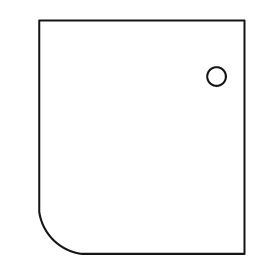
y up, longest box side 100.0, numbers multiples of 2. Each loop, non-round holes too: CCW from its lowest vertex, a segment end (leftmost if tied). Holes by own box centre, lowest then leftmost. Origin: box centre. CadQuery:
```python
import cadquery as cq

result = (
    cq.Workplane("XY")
    .moveTo(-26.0, -50.0)
    .lineTo(44.0, -50.0)
    .lineTo(44.0, 50.0)
    .lineTo(-44.0, 50.0)
    .lineTo(-44.0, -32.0)
    .threePointArc((-38.0, -44.0), (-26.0, -50.0))
    .close()
    .moveTo(32.0, 26.0)
    .circle(4.0)
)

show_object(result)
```